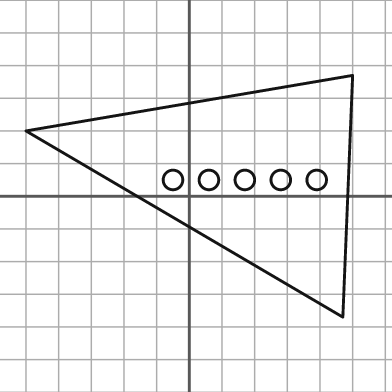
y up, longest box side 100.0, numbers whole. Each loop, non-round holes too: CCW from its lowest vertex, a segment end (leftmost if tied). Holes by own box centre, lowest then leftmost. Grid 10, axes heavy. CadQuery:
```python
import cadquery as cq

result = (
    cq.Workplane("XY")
    .moveTo(47.0, -37.0)
    .lineTo(50.0, 37.0)
    .lineTo(-50.0, 20.0)
    .close()
    .moveTo(-5.0, 5.0)
    .circle(3.0)
    .moveTo(6.0, 5.0)
    .circle(3.0)
    .moveTo(17.0, 5.0)
    .circle(3.0)
    .moveTo(28.0, 5.0)
    .circle(3.0)
    .moveTo(39.0, 5.0)
    .circle(3.0)
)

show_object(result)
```